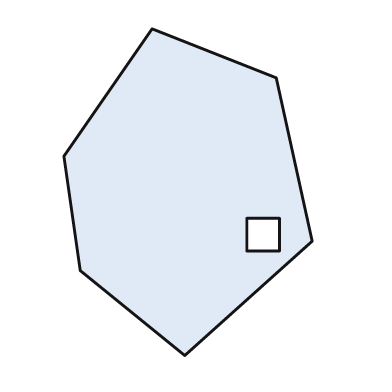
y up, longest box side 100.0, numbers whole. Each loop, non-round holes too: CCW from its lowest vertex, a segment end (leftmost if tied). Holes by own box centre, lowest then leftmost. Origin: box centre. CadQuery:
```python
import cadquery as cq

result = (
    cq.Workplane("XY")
    .moveTo(-1.0, -50.0)
    .lineTo(38.0, -15.0)
    .lineTo(27.0, 35.0)
    .lineTo(-11.0, 50.0)
    .lineTo(-38.0, 11.0)
    .lineTo(-33.0, -24.0)
    .close()
    .moveTo(18.0, -18.0)
    .lineTo(28.0, -18.0)
    .lineTo(28.0, -8.0)
    .lineTo(18.0, -8.0)
    .close()
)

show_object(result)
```